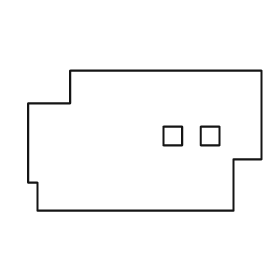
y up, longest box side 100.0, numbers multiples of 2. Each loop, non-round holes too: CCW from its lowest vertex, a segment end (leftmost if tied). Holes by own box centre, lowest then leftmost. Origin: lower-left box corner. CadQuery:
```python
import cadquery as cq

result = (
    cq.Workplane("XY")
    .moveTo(4.0, 0.0)
    .lineTo(88.0, 0.0)
    .lineTo(88.0, 22.0)
    .lineTo(100.0, 22.0)
    .lineTo(100.0, 60.0)
    .lineTo(18.0, 60.0)
    .lineTo(18.0, 46.0)
    .lineTo(0.0, 46.0)
    .lineTo(0.0, 12.0)
    .lineTo(4.0, 12.0)
    .close()
    .moveTo(58.0, 28.0)
    .lineTo(66.0, 28.0)
    .lineTo(66.0, 36.0)
    .lineTo(58.0, 36.0)
    .close()
    .moveTo(74.0, 28.0)
    .lineTo(82.0, 28.0)
    .lineTo(82.0, 36.0)
    .lineTo(74.0, 36.0)
    .close()
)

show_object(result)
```